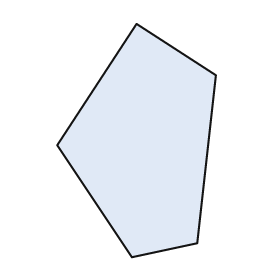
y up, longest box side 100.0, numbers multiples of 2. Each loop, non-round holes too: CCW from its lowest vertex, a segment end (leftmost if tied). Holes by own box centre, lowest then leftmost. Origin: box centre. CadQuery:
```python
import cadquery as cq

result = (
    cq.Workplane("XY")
    .moveTo(-2.0, -50.0)
    .lineTo(26.0, -44.0)
    .lineTo(34.0, 28.0)
    .lineTo(0.0, 50.0)
    .lineTo(-34.0, -2.0)
    .close()
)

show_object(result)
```